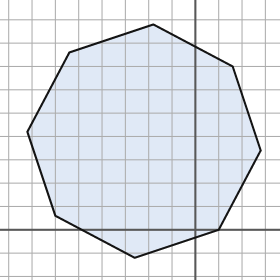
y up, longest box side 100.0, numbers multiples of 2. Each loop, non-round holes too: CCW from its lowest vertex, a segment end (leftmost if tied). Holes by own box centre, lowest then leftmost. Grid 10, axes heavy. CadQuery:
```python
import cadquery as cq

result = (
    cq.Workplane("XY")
    .moveTo(-26.0, -12.0)
    .lineTo(10.0, 0.0)
    .lineTo(28.0, 34.0)
    .lineTo(16.0, 70.0)
    .lineTo(-18.0, 88.0)
    .lineTo(-54.0, 76.0)
    .lineTo(-72.0, 42.0)
    .lineTo(-60.0, 6.0)
    .close()
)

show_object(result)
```